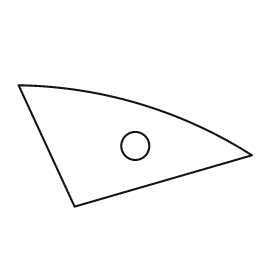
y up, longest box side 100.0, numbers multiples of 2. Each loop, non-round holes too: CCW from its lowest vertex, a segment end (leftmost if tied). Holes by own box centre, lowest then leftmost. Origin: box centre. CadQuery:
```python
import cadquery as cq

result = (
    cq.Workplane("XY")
    .moveTo(-26.0, -26.0)
    .lineTo(50.0, -4.0)
    .threePointArc((2.0, 18.0), (-50.0, 26.0))
    .close()
    .moveTo(0.0, 0.0)
    .circle(6.0)
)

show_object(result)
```